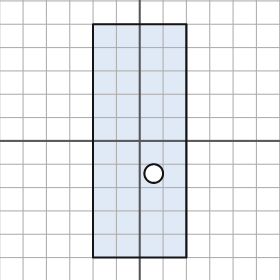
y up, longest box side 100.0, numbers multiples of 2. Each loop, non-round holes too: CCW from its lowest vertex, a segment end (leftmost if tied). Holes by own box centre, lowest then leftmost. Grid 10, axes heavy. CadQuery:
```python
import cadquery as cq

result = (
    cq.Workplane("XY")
    .moveTo(-20.0, -50.0)
    .lineTo(20.0, -50.0)
    .lineTo(20.0, 50.0)
    .lineTo(-20.0, 50.0)
    .close()
    .moveTo(6.0, -14.0)
    .circle(4.0)
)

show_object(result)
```